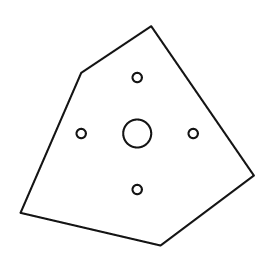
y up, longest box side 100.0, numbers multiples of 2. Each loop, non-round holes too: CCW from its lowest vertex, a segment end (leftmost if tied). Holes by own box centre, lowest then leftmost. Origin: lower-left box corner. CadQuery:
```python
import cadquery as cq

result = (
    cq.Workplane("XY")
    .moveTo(60.0, 0.0)
    .lineTo(100.0, 30.0)
    .lineTo(56.0, 94.0)
    .lineTo(26.0, 74.0)
    .lineTo(0.0, 14.0)
    .close()
    .moveTo(50.0, 24.0)
    .circle(2.0)
    .moveTo(26.0, 48.0)
    .circle(2.0)
    .moveTo(50.0, 48.0)
    .circle(6.0)
    .moveTo(74.0, 48.0)
    .circle(2.0)
    .moveTo(50.0, 72.0)
    .circle(2.0)
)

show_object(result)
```